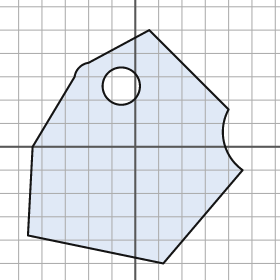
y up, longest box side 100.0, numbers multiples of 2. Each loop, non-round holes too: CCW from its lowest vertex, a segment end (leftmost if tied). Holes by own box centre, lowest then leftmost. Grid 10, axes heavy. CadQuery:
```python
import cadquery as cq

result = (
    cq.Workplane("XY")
    .moveTo(12.0, -50.0)
    .lineTo(46.0, -10.0)
    .threePointArc((38.0, 2.0), (40.0, 16.0))
    .lineTo(6.0, 50.0)
    .lineTo(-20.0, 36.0)
    .threePointArc((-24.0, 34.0), (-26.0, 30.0))
    .lineTo(-44.0, 0.0)
    .lineTo(-46.0, -38.0)
    .close()
    .moveTo(-6.0, 26.0)
    .circle(8.0)
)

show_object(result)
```